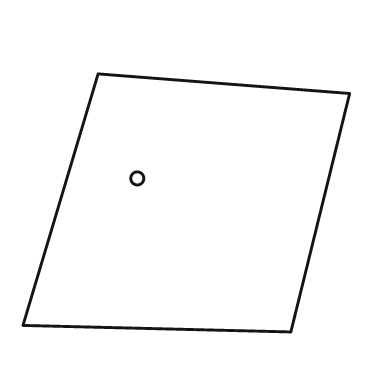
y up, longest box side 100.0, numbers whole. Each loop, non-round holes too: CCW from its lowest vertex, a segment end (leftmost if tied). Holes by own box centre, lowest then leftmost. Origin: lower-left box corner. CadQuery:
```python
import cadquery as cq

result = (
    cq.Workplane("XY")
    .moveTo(82.0, 0.0)
    .lineTo(100.0, 73.0)
    .lineTo(23.0, 79.0)
    .lineTo(0.0, 2.0)
    .close()
    .moveTo(35.0, 47.0)
    .circle(2.0)
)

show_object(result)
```